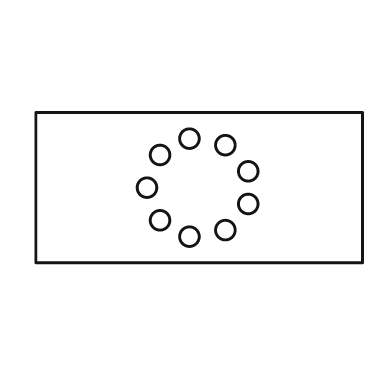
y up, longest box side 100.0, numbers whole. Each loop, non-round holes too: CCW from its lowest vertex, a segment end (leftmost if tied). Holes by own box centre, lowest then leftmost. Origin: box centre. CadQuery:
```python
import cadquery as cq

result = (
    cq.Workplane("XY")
    .moveTo(-50.0, -23.0)
    .lineTo(50.0, -23.0)
    .lineTo(50.0, 23.0)
    .lineTo(-50.0, 23.0)
    .close()
    .moveTo(-3.0, -15.0)
    .circle(3.0)
    .moveTo(8.0, -13.0)
    .circle(3.0)
    .moveTo(-12.0, -10.0)
    .circle(3.0)
    .moveTo(15.0, -5.0)
    .circle(3.0)
    .moveTo(-16.0, 0.0)
    .circle(3.0)
    .moveTo(15.0, 5.0)
    .circle(3.0)
    .moveTo(-12.0, 10.0)
    .circle(3.0)
    .moveTo(8.0, 13.0)
    .circle(3.0)
    .moveTo(-3.0, 15.0)
    .circle(3.0)
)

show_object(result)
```